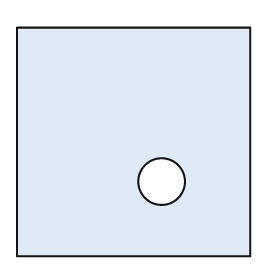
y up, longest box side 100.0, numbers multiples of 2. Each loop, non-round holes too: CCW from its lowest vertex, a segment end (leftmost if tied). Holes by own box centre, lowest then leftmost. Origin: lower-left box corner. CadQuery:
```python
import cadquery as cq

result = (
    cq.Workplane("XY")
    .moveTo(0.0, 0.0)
    .lineTo(100.0, 0.0)
    .lineTo(100.0, 98.0)
    .lineTo(0.0, 98.0)
    .close()
    .moveTo(62.0, 32.0)
    .circle(10.0)
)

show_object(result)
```